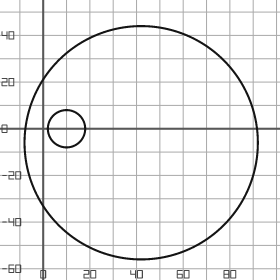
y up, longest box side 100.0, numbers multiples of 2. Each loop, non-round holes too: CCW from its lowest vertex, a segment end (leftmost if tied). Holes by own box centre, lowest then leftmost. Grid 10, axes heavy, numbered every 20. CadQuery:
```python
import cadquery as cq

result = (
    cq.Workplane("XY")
    .moveTo(42.0, -6.0)
    .circle(50.0)
    .moveTo(10.0, 0.0)
    .circle(8.0)
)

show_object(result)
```